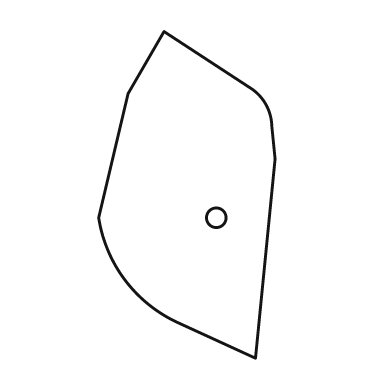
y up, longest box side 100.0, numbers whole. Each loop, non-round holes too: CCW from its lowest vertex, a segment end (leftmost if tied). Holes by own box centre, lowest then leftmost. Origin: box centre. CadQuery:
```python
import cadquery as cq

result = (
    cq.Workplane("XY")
    .moveTo(21.0, -50.0)
    .lineTo(27.0, 11.0)
    .lineTo(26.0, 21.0)
    .threePointArc((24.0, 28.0), (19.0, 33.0))
    .lineTo(-7.0, 50.0)
    .lineTo(-18.0, 31.0)
    .lineTo(-27.0, -7.0)
    .threePointArc((-19.0, -26.0), (-3.0, -39.0))
    .close()
    .moveTo(9.0, -7.0)
    .circle(3.0)
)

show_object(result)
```